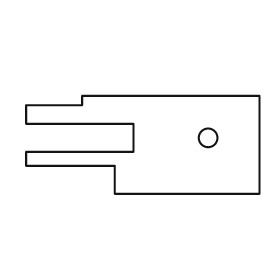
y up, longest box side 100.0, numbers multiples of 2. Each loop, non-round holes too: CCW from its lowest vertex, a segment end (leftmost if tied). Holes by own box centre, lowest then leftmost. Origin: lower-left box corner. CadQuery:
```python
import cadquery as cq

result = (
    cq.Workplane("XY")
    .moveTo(38.0, 0.0)
    .lineTo(100.0, 0.0)
    .lineTo(100.0, 42.0)
    .lineTo(24.0, 42.0)
    .lineTo(24.0, 38.0)
    .lineTo(0.0, 38.0)
    .lineTo(0.0, 30.0)
    .lineTo(46.0, 30.0)
    .lineTo(46.0, 18.0)
    .lineTo(0.0, 18.0)
    .lineTo(0.0, 12.0)
    .lineTo(38.0, 12.0)
    .close()
    .moveTo(78.0, 24.0)
    .circle(4.0)
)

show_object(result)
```